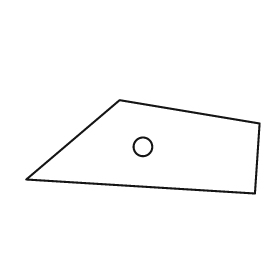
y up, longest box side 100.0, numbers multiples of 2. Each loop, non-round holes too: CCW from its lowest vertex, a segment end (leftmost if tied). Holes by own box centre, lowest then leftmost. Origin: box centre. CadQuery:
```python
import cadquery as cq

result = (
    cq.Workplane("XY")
    .moveTo(48.0, -20.0)
    .lineTo(50.0, 10.0)
    .lineTo(-10.0, 20.0)
    .lineTo(-50.0, -14.0)
    .close()
    .moveTo(0.0, 0.0)
    .circle(4.0)
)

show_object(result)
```